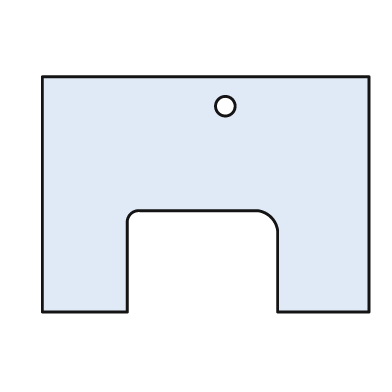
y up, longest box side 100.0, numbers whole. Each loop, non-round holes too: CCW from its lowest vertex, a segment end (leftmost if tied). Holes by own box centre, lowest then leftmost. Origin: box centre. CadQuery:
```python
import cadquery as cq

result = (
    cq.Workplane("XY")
    .moveTo(-50.0, -36.0)
    .lineTo(-24.0, -36.0)
    .lineTo(-24.0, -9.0)
    .threePointArc((-23.0, -6.0), (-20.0, -5.0))
    .lineTo(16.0, -5.0)
    .threePointArc((20.0, -7.0), (22.0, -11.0))
    .lineTo(22.0, -36.0)
    .lineTo(50.0, -36.0)
    .lineTo(50.0, 36.0)
    .lineTo(-50.0, 36.0)
    .close()
    .moveTo(6.0, 27.0)
    .circle(3.0)
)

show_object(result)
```